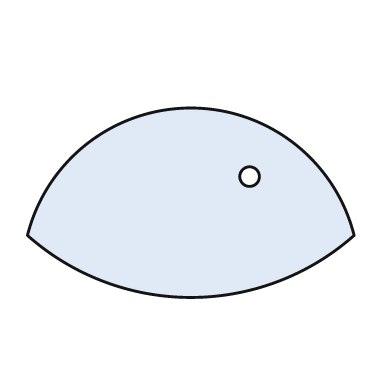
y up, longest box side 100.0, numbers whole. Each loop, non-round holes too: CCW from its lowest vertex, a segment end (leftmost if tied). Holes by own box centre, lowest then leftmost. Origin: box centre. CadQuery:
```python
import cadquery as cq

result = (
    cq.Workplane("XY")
    .moveTo(-50.0, -10.0)
    .threePointArc((0.0, -29.0), (50.0, -10.0))
    .threePointArc((0.0, 29.0), (-50.0, -10.0))
    .close()
    .moveTo(18.0, 8.0)
    .circle(3.0)
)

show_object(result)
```